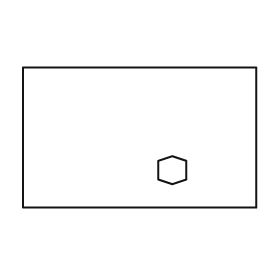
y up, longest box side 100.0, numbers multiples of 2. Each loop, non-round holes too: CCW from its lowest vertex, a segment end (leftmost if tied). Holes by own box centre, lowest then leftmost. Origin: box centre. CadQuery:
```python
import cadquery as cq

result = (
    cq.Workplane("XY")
    .moveTo(-50.0, -30.0)
    .lineTo(50.0, -30.0)
    .lineTo(50.0, 30.0)
    .lineTo(-50.0, 30.0)
    .close()
    .moveTo(14.0, -20.0)
    .lineTo(20.0, -18.0)
    .lineTo(20.0, -10.0)
    .lineTo(14.0, -8.0)
    .lineTo(8.0, -10.0)
    .lineTo(8.0, -18.0)
    .close()
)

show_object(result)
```